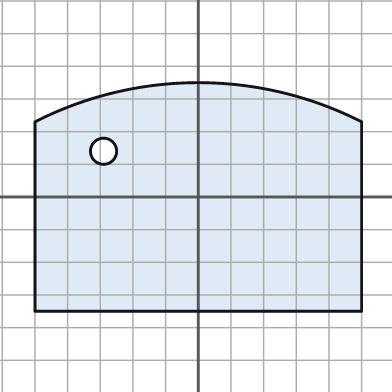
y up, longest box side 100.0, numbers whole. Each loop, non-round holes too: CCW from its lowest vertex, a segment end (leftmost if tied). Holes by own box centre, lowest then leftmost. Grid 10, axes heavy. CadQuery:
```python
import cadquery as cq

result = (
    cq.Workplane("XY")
    .moveTo(-50.0, -35.0)
    .lineTo(50.0, -35.0)
    .lineTo(50.0, 23.0)
    .threePointArc((0.0, 35.0), (-50.0, 23.0))
    .close()
    .moveTo(-29.0, 14.0)
    .circle(4.0)
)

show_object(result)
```